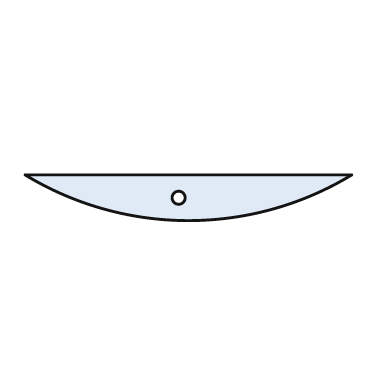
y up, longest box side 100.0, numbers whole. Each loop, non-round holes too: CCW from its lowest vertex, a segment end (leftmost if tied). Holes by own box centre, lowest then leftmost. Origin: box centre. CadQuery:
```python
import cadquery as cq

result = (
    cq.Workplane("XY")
    .moveTo(-50.0, 7.0)
    .threePointArc((0.0, -7.0), (50.0, 7.0))
    .close()
    .moveTo(-3.0, 0.0)
    .circle(2.0)
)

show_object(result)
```